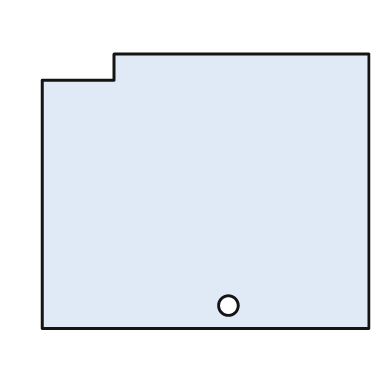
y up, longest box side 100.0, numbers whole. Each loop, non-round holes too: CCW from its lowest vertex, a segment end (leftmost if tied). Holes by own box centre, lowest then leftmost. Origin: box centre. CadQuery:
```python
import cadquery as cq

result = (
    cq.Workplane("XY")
    .moveTo(-50.0, -42.0)
    .lineTo(50.0, -42.0)
    .lineTo(50.0, 42.0)
    .lineTo(-28.0, 42.0)
    .lineTo(-28.0, 34.0)
    .lineTo(-50.0, 34.0)
    .close()
    .moveTo(7.0, -35.0)
    .circle(3.0)
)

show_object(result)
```